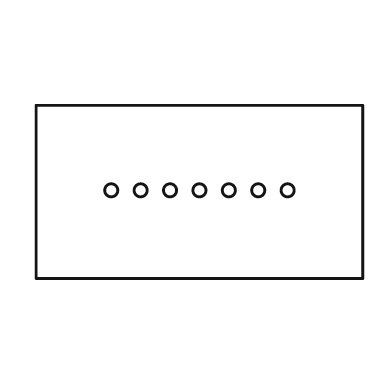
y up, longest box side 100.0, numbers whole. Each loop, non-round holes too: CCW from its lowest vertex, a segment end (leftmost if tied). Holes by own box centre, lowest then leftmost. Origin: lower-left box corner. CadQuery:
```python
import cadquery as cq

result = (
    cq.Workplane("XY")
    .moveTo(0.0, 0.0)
    .lineTo(100.0, 0.0)
    .lineTo(100.0, 53.0)
    .lineTo(0.0, 53.0)
    .close()
    .moveTo(23.0, 27.0)
    .circle(2.0)
    .moveTo(32.0, 27.0)
    .circle(2.0)
    .moveTo(41.0, 27.0)
    .circle(2.0)
    .moveTo(50.0, 27.0)
    .circle(2.0)
    .moveTo(59.0, 27.0)
    .circle(2.0)
    .moveTo(68.0, 27.0)
    .circle(2.0)
    .moveTo(77.0, 27.0)
    .circle(2.0)
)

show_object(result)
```